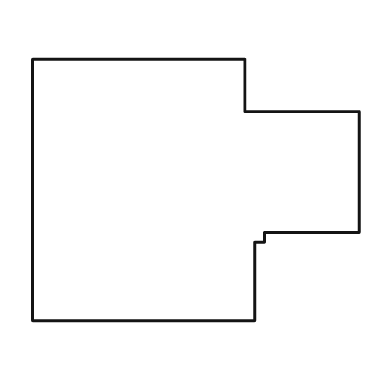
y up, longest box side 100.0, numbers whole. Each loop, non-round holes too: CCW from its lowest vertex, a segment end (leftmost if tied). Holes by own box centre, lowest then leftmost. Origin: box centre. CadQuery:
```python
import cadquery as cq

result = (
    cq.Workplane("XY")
    .moveTo(-50.0, -40.0)
    .lineTo(18.0, -40.0)
    .lineTo(18.0, -16.0)
    .lineTo(21.0, -16.0)
    .lineTo(21.0, -13.0)
    .lineTo(50.0, -13.0)
    .lineTo(50.0, 24.0)
    .lineTo(15.0, 24.0)
    .lineTo(15.0, 40.0)
    .lineTo(-50.0, 40.0)
    .close()
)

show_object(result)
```